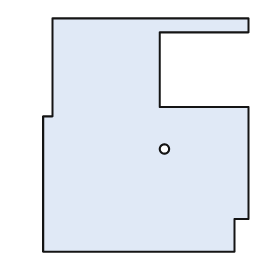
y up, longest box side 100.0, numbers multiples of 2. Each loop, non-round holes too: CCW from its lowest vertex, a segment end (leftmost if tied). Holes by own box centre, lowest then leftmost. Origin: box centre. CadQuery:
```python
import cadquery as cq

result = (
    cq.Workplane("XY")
    .moveTo(-44.0, -50.0)
    .lineTo(38.0, -50.0)
    .lineTo(38.0, -36.0)
    .lineTo(44.0, -36.0)
    .lineTo(44.0, 12.0)
    .lineTo(6.0, 12.0)
    .lineTo(6.0, 44.0)
    .lineTo(44.0, 44.0)
    .lineTo(44.0, 50.0)
    .lineTo(-40.0, 50.0)
    .lineTo(-40.0, 8.0)
    .lineTo(-44.0, 8.0)
    .close()
    .moveTo(8.0, -6.0)
    .circle(2.0)
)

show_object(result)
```